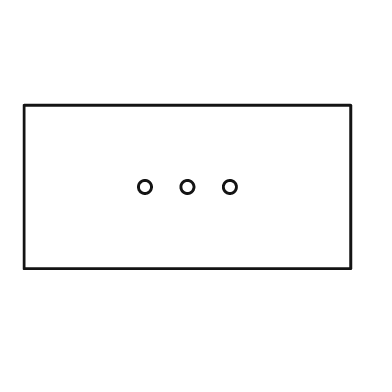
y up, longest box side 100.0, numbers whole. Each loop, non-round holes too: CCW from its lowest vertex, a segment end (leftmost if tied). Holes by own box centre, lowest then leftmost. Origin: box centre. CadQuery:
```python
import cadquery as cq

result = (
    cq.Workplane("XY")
    .moveTo(-50.0, -25.0)
    .lineTo(50.0, -25.0)
    .lineTo(50.0, 25.0)
    .lineTo(-50.0, 25.0)
    .close()
    .moveTo(-13.0, 0.0)
    .circle(2.0)
    .moveTo(0.0, 0.0)
    .circle(2.0)
    .moveTo(13.0, 0.0)
    .circle(2.0)
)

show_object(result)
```